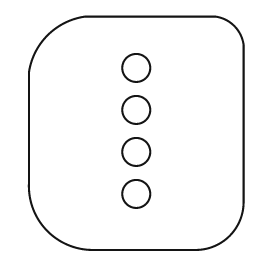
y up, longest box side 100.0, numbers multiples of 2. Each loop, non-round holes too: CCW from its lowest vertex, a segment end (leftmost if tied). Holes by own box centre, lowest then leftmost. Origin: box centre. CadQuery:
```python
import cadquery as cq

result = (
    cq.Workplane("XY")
    .moveTo(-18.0, -50.0)
    .lineTo(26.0, -50.0)
    .threePointArc((40.0, -44.0), (46.0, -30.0))
    .lineTo(46.0, 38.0)
    .threePointArc((42.0, 46.0), (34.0, 50.0))
    .lineTo(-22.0, 50.0)
    .threePointArc((-38.0, 42.0), (-46.0, 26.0))
    .lineTo(-46.0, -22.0)
    .threePointArc((-38.0, -42.0), (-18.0, -50.0))
    .close()
    .moveTo(0.0, -26.0)
    .circle(6.0)
    .moveTo(0.0, -8.0)
    .circle(6.0)
    .moveTo(0.0, 10.0)
    .circle(6.0)
    .moveTo(0.0, 28.0)
    .circle(6.0)
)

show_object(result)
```